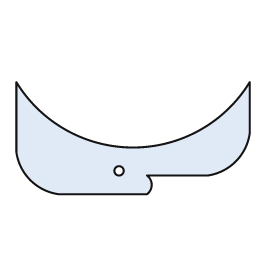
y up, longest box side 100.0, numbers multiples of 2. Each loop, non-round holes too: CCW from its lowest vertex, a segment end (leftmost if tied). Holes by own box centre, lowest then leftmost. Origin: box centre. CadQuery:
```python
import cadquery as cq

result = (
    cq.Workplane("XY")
    .moveTo(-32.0, -24.0)
    .lineTo(6.0, -24.0)
    .threePointArc((8.0, -20.0), (6.0, -16.0))
    .lineTo(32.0, -16.0)
    .threePointArc((44.0, -10.0), (50.0, 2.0))
    .lineTo(50.0, 24.0)
    .threePointArc((0.0, -4.0), (-50.0, 24.0))
    .lineTo(-50.0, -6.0)
    .threePointArc((-44.0, -18.0), (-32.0, -24.0))
    .close()
    .moveTo(-6.0, -14.0)
    .circle(2.0)
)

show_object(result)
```